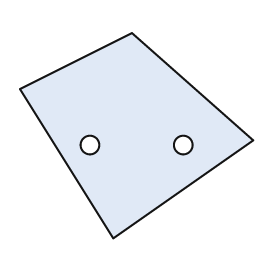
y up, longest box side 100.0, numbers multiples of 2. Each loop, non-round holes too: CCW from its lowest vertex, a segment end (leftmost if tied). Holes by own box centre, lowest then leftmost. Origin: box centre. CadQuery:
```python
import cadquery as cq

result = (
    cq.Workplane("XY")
    .moveTo(-10.0, -44.0)
    .lineTo(50.0, -2.0)
    .lineTo(-2.0, 44.0)
    .lineTo(-50.0, 20.0)
    .close()
    .moveTo(-20.0, -4.0)
    .circle(4.0)
    .moveTo(20.0, -4.0)
    .circle(4.0)
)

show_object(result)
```